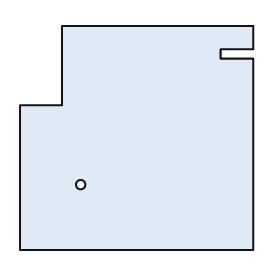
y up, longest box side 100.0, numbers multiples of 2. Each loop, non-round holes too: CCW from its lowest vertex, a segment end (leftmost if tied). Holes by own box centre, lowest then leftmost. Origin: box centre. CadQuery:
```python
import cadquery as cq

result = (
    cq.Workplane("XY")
    .moveTo(-50.0, -48.0)
    .lineTo(50.0, -48.0)
    .lineTo(50.0, 34.0)
    .lineTo(36.0, 34.0)
    .lineTo(36.0, 38.0)
    .lineTo(50.0, 38.0)
    .lineTo(50.0, 48.0)
    .lineTo(-32.0, 48.0)
    .lineTo(-32.0, 14.0)
    .lineTo(-50.0, 14.0)
    .close()
    .moveTo(-24.0, -20.0)
    .circle(2.0)
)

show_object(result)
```